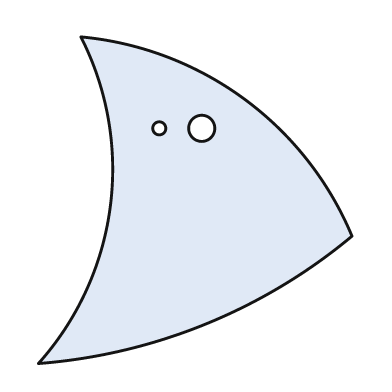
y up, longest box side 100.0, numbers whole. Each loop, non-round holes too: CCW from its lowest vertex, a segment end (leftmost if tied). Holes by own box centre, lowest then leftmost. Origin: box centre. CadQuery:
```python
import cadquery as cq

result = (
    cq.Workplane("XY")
    .moveTo(-48.0, -50.0)
    .threePointArc((3.0, -38.0), (48.0, -11.0))
    .threePointArc((15.0, 31.0), (-35.0, 50.0))
    .threePointArc((-26.0, -2.0), (-48.0, -50.0))
    .close()
    .moveTo(-11.0, 22.0)
    .circle(2.0)
    .moveTo(2.0, 22.0)
    .circle(4.0)
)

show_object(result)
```